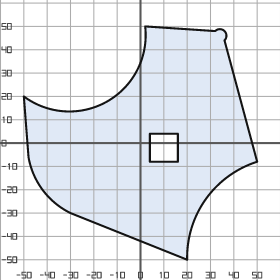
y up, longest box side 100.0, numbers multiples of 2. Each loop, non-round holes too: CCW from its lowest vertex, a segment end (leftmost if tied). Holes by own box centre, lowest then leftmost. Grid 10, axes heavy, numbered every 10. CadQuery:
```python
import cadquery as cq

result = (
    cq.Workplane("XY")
    .moveTo(20.0, -50.0)
    .threePointArc((28.0, -24.0), (50.0, -8.0))
    .lineTo(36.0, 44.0)
    .threePointArc((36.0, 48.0), (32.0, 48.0))
    .lineTo(2.0, 50.0)
    .threePointArc((-14.0, 18.0), (-50.0, 20.0))
    .lineTo(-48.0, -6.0)
    .threePointArc((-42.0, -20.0), (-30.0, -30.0))
    .close()
    .moveTo(4.0, -8.0)
    .lineTo(16.0, -8.0)
    .lineTo(16.0, 4.0)
    .lineTo(4.0, 4.0)
    .close()
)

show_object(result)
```